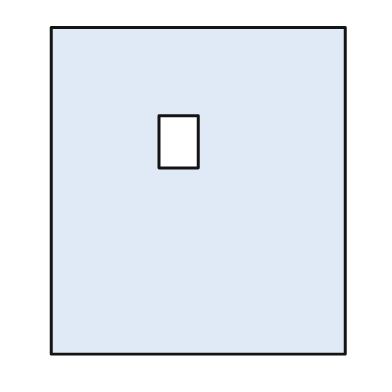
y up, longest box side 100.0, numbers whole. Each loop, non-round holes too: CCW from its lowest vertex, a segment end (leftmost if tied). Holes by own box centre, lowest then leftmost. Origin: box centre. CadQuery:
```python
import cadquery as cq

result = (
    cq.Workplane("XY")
    .moveTo(-45.0, -50.0)
    .lineTo(45.0, -50.0)
    .lineTo(45.0, 50.0)
    .lineTo(-45.0, 50.0)
    .close()
    .moveTo(-12.0, 7.0)
    .lineTo(0.0, 7.0)
    .lineTo(0.0, 23.0)
    .lineTo(-12.0, 23.0)
    .close()
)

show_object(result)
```